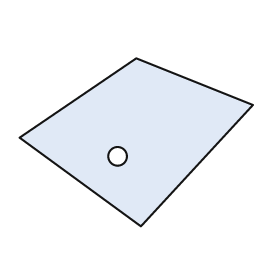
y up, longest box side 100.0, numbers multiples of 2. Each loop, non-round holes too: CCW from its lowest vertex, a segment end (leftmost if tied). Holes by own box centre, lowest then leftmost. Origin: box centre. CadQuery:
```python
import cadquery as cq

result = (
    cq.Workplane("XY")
    .moveTo(2.0, -36.0)
    .lineTo(50.0, 16.0)
    .lineTo(0.0, 36.0)
    .lineTo(-50.0, 2.0)
    .close()
    .moveTo(-8.0, -6.0)
    .circle(4.0)
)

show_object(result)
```